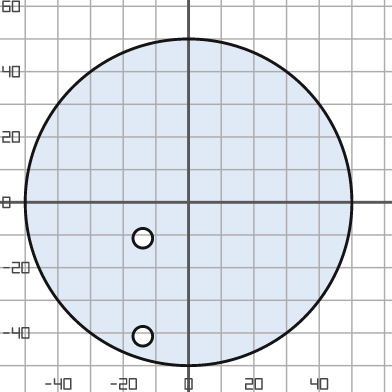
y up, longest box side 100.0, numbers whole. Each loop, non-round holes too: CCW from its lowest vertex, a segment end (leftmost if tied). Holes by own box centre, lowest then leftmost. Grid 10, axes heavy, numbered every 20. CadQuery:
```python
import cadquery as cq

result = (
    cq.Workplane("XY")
    .moveTo(0.0, 0.0)
    .circle(50.0)
    .moveTo(-14.0, -41.0)
    .circle(3.0)
    .moveTo(-14.0, -11.0)
    .circle(3.0)
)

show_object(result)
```